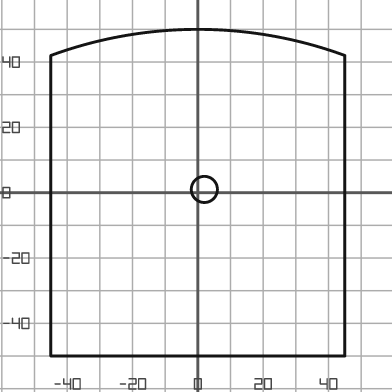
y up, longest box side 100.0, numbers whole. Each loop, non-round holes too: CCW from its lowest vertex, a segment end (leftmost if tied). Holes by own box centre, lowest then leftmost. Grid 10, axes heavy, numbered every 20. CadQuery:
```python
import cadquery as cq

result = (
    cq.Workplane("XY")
    .moveTo(-45.0, -50.0)
    .lineTo(45.0, -50.0)
    .lineTo(45.0, 42.0)
    .threePointArc((0.0, 50.0), (-45.0, 42.0))
    .close()
    .moveTo(2.0, 1.0)
    .circle(4.0)
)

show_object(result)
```